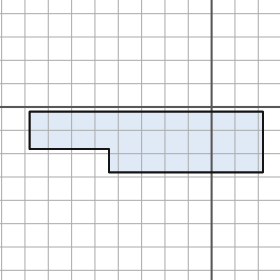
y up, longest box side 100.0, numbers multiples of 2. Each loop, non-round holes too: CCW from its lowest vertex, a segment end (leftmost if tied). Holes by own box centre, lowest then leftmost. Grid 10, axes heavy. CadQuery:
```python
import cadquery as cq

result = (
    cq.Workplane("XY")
    .moveTo(-44.0, -28.0)
    .lineTo(22.0, -28.0)
    .lineTo(22.0, -2.0)
    .lineTo(-78.0, -2.0)
    .lineTo(-78.0, -18.0)
    .lineTo(-44.0, -18.0)
    .close()
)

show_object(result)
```